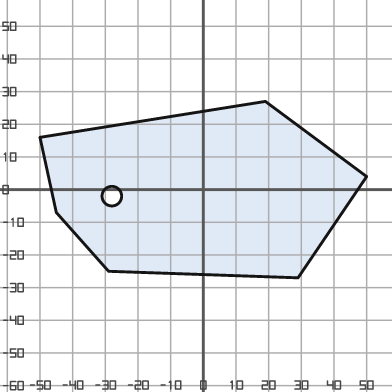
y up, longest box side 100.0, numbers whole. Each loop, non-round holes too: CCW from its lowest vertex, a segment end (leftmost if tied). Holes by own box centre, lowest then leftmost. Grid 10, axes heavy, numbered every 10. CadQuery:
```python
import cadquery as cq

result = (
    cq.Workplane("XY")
    .moveTo(29.0, -27.0)
    .lineTo(50.0, 4.0)
    .lineTo(19.0, 27.0)
    .lineTo(-50.0, 16.0)
    .lineTo(-45.0, -7.0)
    .lineTo(-29.0, -25.0)
    .close()
    .moveTo(-28.0, -2.0)
    .circle(3.0)
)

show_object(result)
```